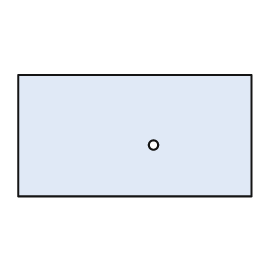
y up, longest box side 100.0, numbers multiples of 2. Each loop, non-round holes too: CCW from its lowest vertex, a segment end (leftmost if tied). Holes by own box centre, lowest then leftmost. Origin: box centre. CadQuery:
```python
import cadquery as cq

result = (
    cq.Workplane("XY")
    .moveTo(-50.0, -26.0)
    .lineTo(50.0, -26.0)
    .lineTo(50.0, 26.0)
    .lineTo(-50.0, 26.0)
    .close()
    .moveTo(8.0, -4.0)
    .circle(2.0)
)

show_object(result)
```